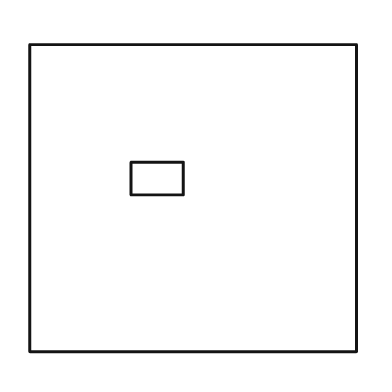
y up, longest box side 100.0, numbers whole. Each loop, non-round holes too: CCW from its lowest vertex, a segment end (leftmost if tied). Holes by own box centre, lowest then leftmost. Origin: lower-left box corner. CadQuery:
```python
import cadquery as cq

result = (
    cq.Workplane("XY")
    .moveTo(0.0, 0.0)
    .lineTo(100.0, 0.0)
    .lineTo(100.0, 94.0)
    .lineTo(0.0, 94.0)
    .close()
    .moveTo(31.0, 48.0)
    .lineTo(47.0, 48.0)
    .lineTo(47.0, 58.0)
    .lineTo(31.0, 58.0)
    .close()
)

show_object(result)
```